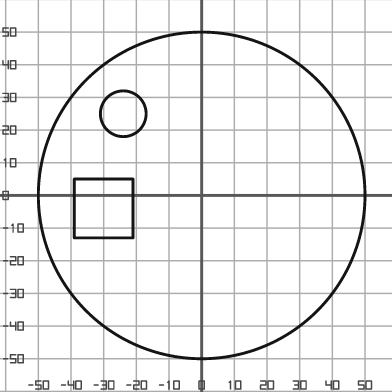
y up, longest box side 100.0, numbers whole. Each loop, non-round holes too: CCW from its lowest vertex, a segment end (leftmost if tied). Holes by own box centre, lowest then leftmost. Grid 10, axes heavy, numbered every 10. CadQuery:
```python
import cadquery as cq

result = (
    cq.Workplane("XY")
    .moveTo(0.0, 0.0)
    .circle(50.0)
    .moveTo(-39.0, -13.0)
    .lineTo(-21.0, -13.0)
    .lineTo(-21.0, 5.0)
    .lineTo(-39.0, 5.0)
    .close()
    .moveTo(-24.0, 25.0)
    .circle(7.0)
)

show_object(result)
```